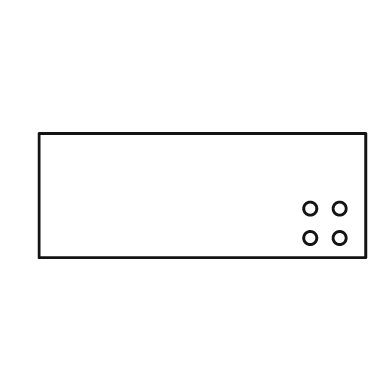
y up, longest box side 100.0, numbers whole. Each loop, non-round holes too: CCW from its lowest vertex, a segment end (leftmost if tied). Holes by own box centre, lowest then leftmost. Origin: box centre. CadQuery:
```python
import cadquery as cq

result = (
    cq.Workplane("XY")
    .moveTo(-50.0, -19.0)
    .lineTo(50.0, -19.0)
    .lineTo(50.0, 19.0)
    .lineTo(-50.0, 19.0)
    .close()
    .moveTo(33.0, -13.0)
    .circle(2.0)
    .moveTo(42.0, -13.0)
    .circle(2.0)
    .moveTo(33.0, -4.0)
    .circle(2.0)
    .moveTo(42.0, -4.0)
    .circle(2.0)
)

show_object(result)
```